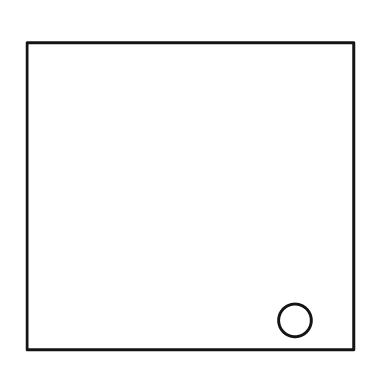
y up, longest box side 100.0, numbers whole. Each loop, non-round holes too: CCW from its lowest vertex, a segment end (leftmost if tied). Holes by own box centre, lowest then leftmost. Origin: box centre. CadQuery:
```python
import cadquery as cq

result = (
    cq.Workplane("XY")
    .moveTo(-50.0, -47.0)
    .lineTo(50.0, -47.0)
    .lineTo(50.0, 47.0)
    .lineTo(-50.0, 47.0)
    .close()
    .moveTo(32.0, -38.0)
    .circle(5.0)
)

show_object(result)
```